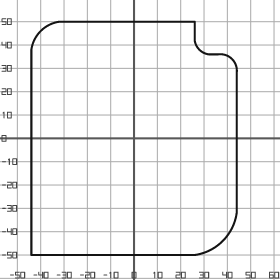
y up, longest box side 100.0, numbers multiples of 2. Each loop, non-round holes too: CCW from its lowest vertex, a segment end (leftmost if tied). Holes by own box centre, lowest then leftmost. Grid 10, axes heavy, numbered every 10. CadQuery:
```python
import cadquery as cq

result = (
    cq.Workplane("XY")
    .moveTo(-44.0, -50.0)
    .lineTo(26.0, -50.0)
    .threePointArc((38.0, -44.0), (44.0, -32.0))
    .lineTo(44.0, 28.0)
    .threePointArc((42.0, 34.0), (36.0, 36.0))
    .lineTo(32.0, 36.0)
    .threePointArc((28.0, 38.0), (26.0, 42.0))
    .lineTo(26.0, 50.0)
    .lineTo(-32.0, 50.0)
    .threePointArc((-40.0, 46.0), (-44.0, 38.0))
    .close()
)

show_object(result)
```